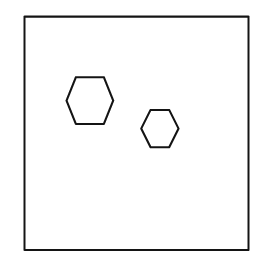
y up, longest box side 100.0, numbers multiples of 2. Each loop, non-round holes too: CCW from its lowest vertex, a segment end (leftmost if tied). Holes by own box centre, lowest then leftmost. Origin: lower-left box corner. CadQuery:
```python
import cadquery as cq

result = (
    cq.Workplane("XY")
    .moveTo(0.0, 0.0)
    .lineTo(96.0, 0.0)
    .lineTo(96.0, 100.0)
    .lineTo(0.0, 100.0)
    .close()
    .moveTo(54.0, 44.0)
    .lineTo(62.0, 44.0)
    .lineTo(66.0, 52.0)
    .lineTo(62.0, 60.0)
    .lineTo(54.0, 60.0)
    .lineTo(50.0, 52.0)
    .close()
    .moveTo(22.0, 54.0)
    .lineTo(34.0, 54.0)
    .lineTo(38.0, 64.0)
    .lineTo(34.0, 74.0)
    .lineTo(22.0, 74.0)
    .lineTo(18.0, 64.0)
    .close()
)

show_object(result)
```